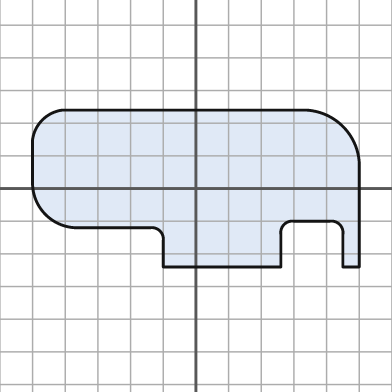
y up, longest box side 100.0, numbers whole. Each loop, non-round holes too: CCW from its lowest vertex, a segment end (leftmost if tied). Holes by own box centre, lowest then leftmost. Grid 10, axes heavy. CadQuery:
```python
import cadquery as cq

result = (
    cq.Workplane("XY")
    .moveTo(-10.0, -24.0)
    .lineTo(26.0, -24.0)
    .lineTo(26.0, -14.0)
    .threePointArc((27.0, -11.0), (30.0, -10.0))
    .lineTo(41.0, -10.0)
    .threePointArc((44.0, -11.0), (45.0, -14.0))
    .lineTo(45.0, -24.0)
    .lineTo(50.0, -24.0)
    .lineTo(50.0, 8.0)
    .threePointArc((45.0, 19.0), (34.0, 24.0))
    .lineTo(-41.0, 24.0)
    .threePointArc((-47.0, 21.0), (-50.0, 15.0))
    .lineTo(-50.0, 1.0)
    .threePointArc((-46.0, -8.0), (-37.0, -12.0))
    .lineTo(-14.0, -12.0)
    .threePointArc((-11.0, -13.0), (-10.0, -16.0))
    .close()
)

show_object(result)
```